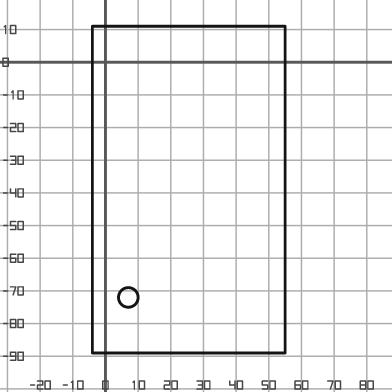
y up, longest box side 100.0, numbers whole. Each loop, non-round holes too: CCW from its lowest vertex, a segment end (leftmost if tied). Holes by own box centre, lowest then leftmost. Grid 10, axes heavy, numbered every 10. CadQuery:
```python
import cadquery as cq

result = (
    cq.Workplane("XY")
    .moveTo(-4.0, -89.0)
    .lineTo(55.0, -89.0)
    .lineTo(55.0, 11.0)
    .lineTo(-4.0, 11.0)
    .close()
    .moveTo(7.0, -72.0)
    .circle(3.0)
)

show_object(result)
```